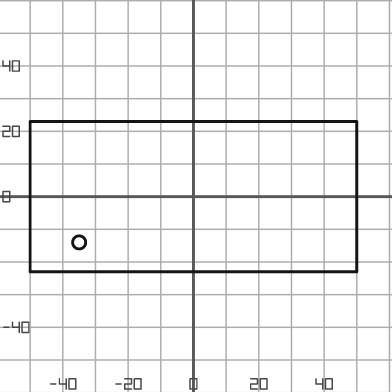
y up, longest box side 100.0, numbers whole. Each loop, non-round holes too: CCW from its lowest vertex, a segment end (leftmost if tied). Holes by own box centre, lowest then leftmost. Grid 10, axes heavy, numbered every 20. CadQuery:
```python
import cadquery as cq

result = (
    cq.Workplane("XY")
    .moveTo(-50.0, -23.0)
    .lineTo(50.0, -23.0)
    .lineTo(50.0, 23.0)
    .lineTo(-50.0, 23.0)
    .close()
    .moveTo(-35.0, -14.0)
    .circle(2.0)
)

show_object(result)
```